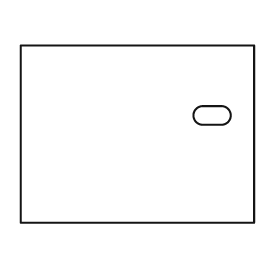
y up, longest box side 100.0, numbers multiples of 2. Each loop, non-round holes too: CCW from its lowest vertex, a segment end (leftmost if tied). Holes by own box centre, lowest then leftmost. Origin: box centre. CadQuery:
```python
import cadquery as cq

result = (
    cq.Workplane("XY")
    .moveTo(-50.0, -38.0)
    .lineTo(50.0, -38.0)
    .lineTo(50.0, 38.0)
    .lineTo(-50.0, 38.0)
    .close()
    .moveTo(28.0, 4.0)
    .lineTo(36.0, 4.0)
    .threePointArc((40.0, 8.0), (36.0, 12.0))
    .lineTo(28.0, 12.0)
    .threePointArc((24.0, 8.0), (28.0, 4.0))
    .close()
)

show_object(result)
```